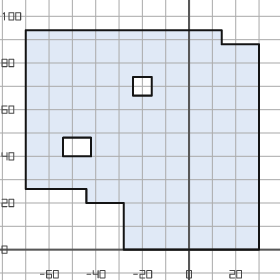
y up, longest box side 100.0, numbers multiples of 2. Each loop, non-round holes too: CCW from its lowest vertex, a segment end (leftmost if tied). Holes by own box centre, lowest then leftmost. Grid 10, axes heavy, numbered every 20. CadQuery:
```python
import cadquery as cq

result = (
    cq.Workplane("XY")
    .moveTo(-28.0, 0.0)
    .lineTo(30.0, 0.0)
    .lineTo(30.0, 88.0)
    .lineTo(14.0, 88.0)
    .lineTo(14.0, 94.0)
    .lineTo(-70.0, 94.0)
    .lineTo(-70.0, 26.0)
    .lineTo(-44.0, 26.0)
    .lineTo(-44.0, 20.0)
    .lineTo(-28.0, 20.0)
    .close()
    .moveTo(-54.0, 40.0)
    .lineTo(-42.0, 40.0)
    .lineTo(-42.0, 48.0)
    .lineTo(-54.0, 48.0)
    .close()
    .moveTo(-24.0, 66.0)
    .lineTo(-16.0, 66.0)
    .lineTo(-16.0, 74.0)
    .lineTo(-24.0, 74.0)
    .close()
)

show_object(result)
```